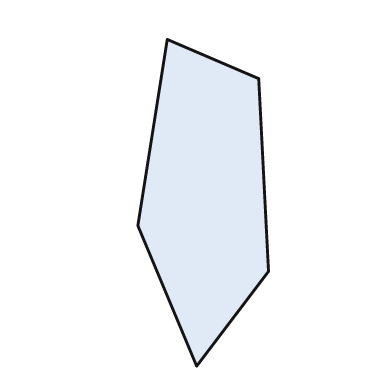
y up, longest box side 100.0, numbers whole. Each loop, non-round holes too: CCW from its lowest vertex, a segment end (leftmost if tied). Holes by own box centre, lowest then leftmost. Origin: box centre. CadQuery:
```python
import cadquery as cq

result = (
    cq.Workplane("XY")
    .moveTo(-2.0, -50.0)
    .lineTo(20.0, -21.0)
    .lineTo(17.0, 38.0)
    .lineTo(-11.0, 50.0)
    .lineTo(-20.0, -7.0)
    .close()
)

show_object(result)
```